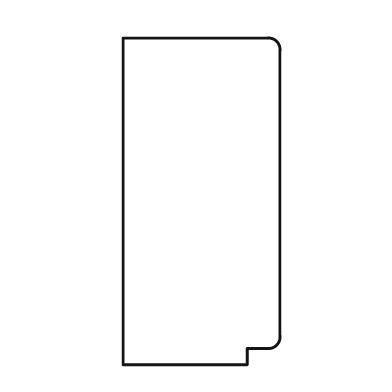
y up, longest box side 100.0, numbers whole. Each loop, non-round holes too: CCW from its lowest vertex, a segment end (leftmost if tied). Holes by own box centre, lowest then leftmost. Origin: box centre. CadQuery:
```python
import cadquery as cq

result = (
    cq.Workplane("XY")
    .moveTo(-24.0, -50.0)
    .lineTo(14.0, -50.0)
    .lineTo(14.0, -45.0)
    .lineTo(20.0, -45.0)
    .threePointArc((23.0, -44.0), (24.0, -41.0))
    .lineTo(24.0, 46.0)
    .threePointArc((23.0, 49.0), (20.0, 50.0))
    .lineTo(-24.0, 50.0)
    .close()
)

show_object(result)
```